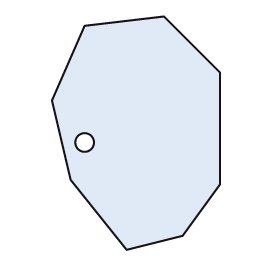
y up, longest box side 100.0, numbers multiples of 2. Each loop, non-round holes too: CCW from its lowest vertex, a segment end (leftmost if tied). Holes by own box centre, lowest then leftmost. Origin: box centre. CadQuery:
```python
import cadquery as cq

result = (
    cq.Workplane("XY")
    .moveTo(-4.0, -50.0)
    .lineTo(20.0, -44.0)
    .lineTo(36.0, -22.0)
    .lineTo(36.0, 26.0)
    .lineTo(12.0, 50.0)
    .lineTo(-22.0, 46.0)
    .lineTo(-36.0, 14.0)
    .lineTo(-28.0, -20.0)
    .close()
    .moveTo(-22.0, -4.0)
    .circle(4.0)
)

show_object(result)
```